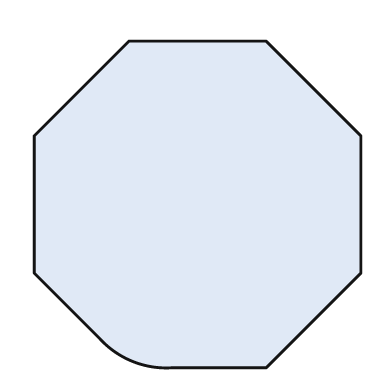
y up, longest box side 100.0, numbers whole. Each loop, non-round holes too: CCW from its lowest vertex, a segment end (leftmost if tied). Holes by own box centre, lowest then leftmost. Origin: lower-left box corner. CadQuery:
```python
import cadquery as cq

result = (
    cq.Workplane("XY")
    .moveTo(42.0, 0.0)
    .lineTo(71.0, 0.0)
    .lineTo(100.0, 29.0)
    .lineTo(100.0, 71.0)
    .lineTo(71.0, 100.0)
    .lineTo(29.0, 100.0)
    .lineTo(0.0, 71.0)
    .lineTo(0.0, 29.0)
    .lineTo(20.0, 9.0)
    .threePointArc((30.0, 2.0), (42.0, 0.0))
    .close()
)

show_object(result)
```